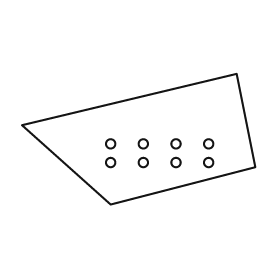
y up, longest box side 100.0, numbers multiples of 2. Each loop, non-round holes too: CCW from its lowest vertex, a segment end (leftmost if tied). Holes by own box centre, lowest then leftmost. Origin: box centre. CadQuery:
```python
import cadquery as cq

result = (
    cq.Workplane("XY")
    .moveTo(-12.0, -28.0)
    .lineTo(50.0, -12.0)
    .lineTo(42.0, 28.0)
    .lineTo(-50.0, 6.0)
    .close()
    .moveTo(-12.0, -10.0)
    .circle(2.0)
    .moveTo(2.0, -10.0)
    .circle(2.0)
    .moveTo(16.0, -10.0)
    .circle(2.0)
    .moveTo(30.0, -10.0)
    .circle(2.0)
    .moveTo(-12.0, -2.0)
    .circle(2.0)
    .moveTo(2.0, -2.0)
    .circle(2.0)
    .moveTo(16.0, -2.0)
    .circle(2.0)
    .moveTo(30.0, -2.0)
    .circle(2.0)
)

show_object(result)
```